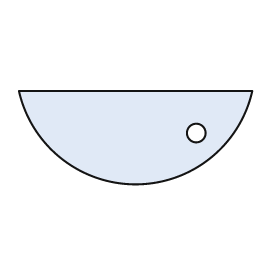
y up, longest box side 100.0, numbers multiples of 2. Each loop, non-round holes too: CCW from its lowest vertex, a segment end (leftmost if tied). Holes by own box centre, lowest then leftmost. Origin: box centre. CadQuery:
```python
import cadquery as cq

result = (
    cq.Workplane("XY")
    .moveTo(-50.0, 20.0)
    .threePointArc((0.0, -20.0), (50.0, 20.0))
    .close()
    .moveTo(26.0, 2.0)
    .circle(4.0)
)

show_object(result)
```